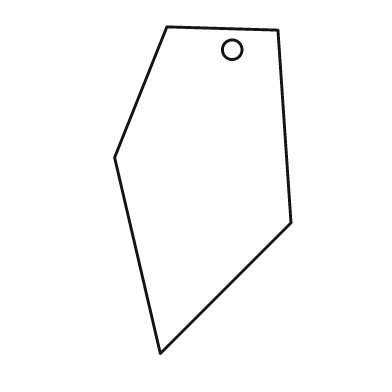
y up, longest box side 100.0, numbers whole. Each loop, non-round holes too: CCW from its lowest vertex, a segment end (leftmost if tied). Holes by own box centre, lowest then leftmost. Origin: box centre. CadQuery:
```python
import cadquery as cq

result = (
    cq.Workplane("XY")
    .moveTo(-13.0, -50.0)
    .lineTo(27.0, -10.0)
    .lineTo(23.0, 49.0)
    .lineTo(-11.0, 50.0)
    .lineTo(-27.0, 10.0)
    .close()
    .moveTo(9.0, 43.0)
    .circle(3.0)
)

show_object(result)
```